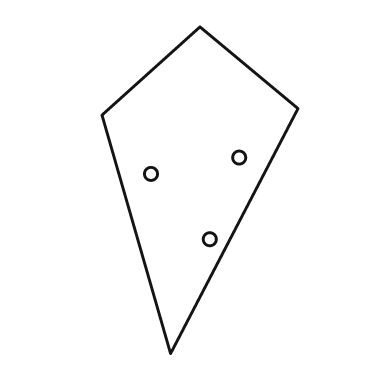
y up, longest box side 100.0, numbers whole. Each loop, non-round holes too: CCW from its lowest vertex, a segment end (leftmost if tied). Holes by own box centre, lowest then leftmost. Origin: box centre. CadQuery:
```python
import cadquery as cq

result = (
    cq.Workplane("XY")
    .moveTo(-9.0, -50.0)
    .lineTo(30.0, 25.0)
    .lineTo(0.0, 50.0)
    .lineTo(-30.0, 23.0)
    .close()
    .moveTo(3.0, -15.0)
    .circle(2.0)
    .moveTo(-15.0, 5.0)
    .circle(2.0)
    .moveTo(12.0, 10.0)
    .circle(2.0)
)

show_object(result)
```